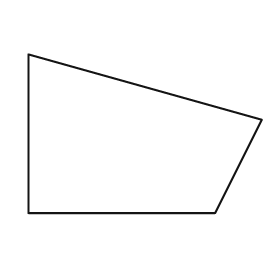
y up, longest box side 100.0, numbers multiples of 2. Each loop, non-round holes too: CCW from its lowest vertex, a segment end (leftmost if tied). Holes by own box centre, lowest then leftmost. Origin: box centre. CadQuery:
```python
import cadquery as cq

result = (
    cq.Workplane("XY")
    .moveTo(-50.0, -34.0)
    .lineTo(30.0, -34.0)
    .lineTo(50.0, 6.0)
    .lineTo(-50.0, 34.0)
    .close()
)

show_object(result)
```